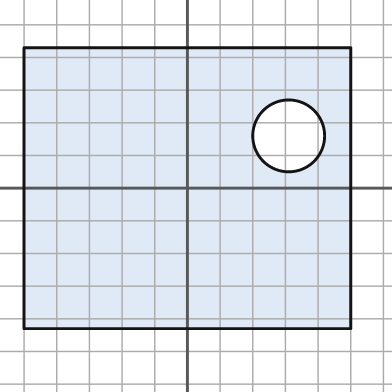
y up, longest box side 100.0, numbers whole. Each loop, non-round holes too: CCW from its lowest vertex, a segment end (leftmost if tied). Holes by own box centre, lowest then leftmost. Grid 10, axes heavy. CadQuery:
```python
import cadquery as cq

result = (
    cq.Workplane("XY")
    .moveTo(-50.0, -43.0)
    .lineTo(50.0, -43.0)
    .lineTo(50.0, 43.0)
    .lineTo(-50.0, 43.0)
    .close()
    .moveTo(31.0, 16.0)
    .circle(11.0)
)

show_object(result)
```